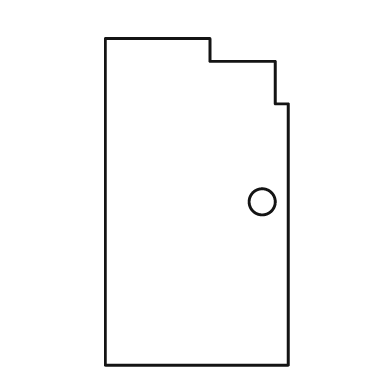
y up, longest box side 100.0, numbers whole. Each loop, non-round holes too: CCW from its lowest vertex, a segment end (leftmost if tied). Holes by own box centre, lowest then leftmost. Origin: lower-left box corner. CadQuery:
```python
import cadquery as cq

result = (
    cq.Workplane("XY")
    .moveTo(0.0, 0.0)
    .lineTo(56.0, 0.0)
    .lineTo(56.0, 80.0)
    .lineTo(52.0, 80.0)
    .lineTo(52.0, 93.0)
    .lineTo(32.0, 93.0)
    .lineTo(32.0, 100.0)
    .lineTo(0.0, 100.0)
    .close()
    .moveTo(48.0, 50.0)
    .circle(4.0)
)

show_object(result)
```